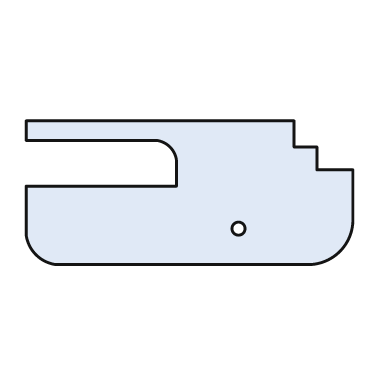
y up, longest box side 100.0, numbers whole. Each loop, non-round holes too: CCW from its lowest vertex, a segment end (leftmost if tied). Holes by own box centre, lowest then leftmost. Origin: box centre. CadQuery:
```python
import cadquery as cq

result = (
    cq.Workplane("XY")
    .moveTo(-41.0, -22.0)
    .lineTo(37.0, -22.0)
    .threePointArc((46.0, -18.0), (50.0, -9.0))
    .lineTo(50.0, 7.0)
    .lineTo(39.0, 7.0)
    .lineTo(39.0, 14.0)
    .lineTo(32.0, 14.0)
    .lineTo(32.0, 22.0)
    .lineTo(-50.0, 22.0)
    .lineTo(-50.0, 16.0)
    .lineTo(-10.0, 16.0)
    .threePointArc((-6.0, 14.0), (-4.0, 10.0))
    .lineTo(-4.0, 2.0)
    .lineTo(-50.0, 2.0)
    .lineTo(-50.0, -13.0)
    .threePointArc((-47.0, -19.0), (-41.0, -22.0))
    .close()
    .moveTo(15.0, -11.0)
    .circle(2.0)
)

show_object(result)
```